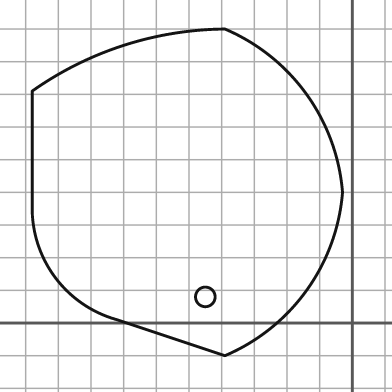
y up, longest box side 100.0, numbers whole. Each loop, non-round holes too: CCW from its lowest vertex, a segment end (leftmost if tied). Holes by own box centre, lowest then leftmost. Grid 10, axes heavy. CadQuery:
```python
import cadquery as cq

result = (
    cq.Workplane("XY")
    .moveTo(-39.0, -10.0)
    .threePointArc((-14.0, 10.0), (-3.0, 40.0))
    .threePointArc((-14.0, 70.0), (-39.0, 90.0))
    .threePointArc((-70.0, 85.0), (-98.0, 71.0))
    .lineTo(-98.0, 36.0)
    .threePointArc((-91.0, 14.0), (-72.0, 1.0))
    .close()
    .moveTo(-45.0, 8.0)
    .circle(3.0)
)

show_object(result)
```